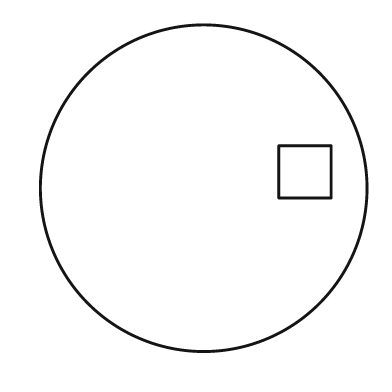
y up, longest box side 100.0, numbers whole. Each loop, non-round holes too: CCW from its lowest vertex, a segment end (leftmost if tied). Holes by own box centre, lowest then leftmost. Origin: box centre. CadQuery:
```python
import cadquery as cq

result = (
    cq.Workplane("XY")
    .moveTo(0.0, 0.0)
    .circle(50.0)
    .moveTo(23.0, -3.0)
    .lineTo(39.0, -3.0)
    .lineTo(39.0, 13.0)
    .lineTo(23.0, 13.0)
    .close()
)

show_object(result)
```